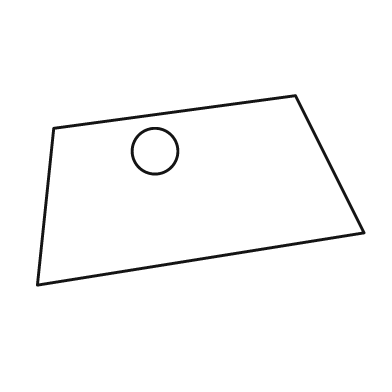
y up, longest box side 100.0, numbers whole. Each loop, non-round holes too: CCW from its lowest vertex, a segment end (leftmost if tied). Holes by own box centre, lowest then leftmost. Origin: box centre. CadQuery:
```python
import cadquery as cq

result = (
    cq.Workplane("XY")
    .moveTo(-50.0, -29.0)
    .lineTo(50.0, -13.0)
    .lineTo(29.0, 29.0)
    .lineTo(-45.0, 19.0)
    .close()
    .moveTo(-14.0, 12.0)
    .circle(7.0)
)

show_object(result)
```